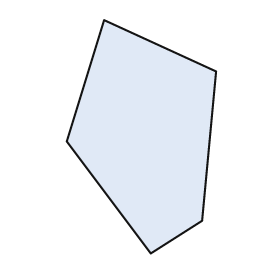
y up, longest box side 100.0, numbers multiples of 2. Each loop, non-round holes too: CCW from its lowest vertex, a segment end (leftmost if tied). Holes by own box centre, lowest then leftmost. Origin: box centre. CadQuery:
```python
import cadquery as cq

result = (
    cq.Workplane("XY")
    .moveTo(4.0, -50.0)
    .lineTo(26.0, -36.0)
    .lineTo(32.0, 28.0)
    .lineTo(-16.0, 50.0)
    .lineTo(-32.0, -2.0)
    .close()
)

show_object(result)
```